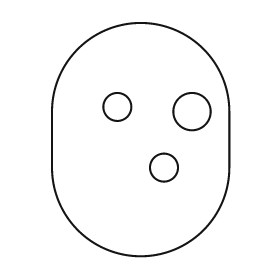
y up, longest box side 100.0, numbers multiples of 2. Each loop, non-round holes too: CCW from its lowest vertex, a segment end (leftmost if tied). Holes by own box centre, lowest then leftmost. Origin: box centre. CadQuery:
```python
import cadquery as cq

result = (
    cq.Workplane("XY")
    .moveTo(-38.0, -12.0)
    .threePointArc((0.0, -50.0), (38.0, -12.0))
    .lineTo(38.0, 12.0)
    .threePointArc((0.0, 50.0), (-38.0, 12.0))
    .close()
    .moveTo(10.0, -12.0)
    .circle(6.0)
    .moveTo(22.0, 12.0)
    .circle(8.0)
    .moveTo(-10.0, 14.0)
    .circle(6.0)
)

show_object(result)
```